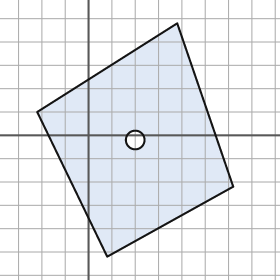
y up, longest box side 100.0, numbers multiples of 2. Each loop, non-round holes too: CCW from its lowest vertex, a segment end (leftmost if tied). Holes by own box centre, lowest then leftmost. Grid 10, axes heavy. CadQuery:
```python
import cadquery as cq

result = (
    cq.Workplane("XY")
    .moveTo(8.0, -52.0)
    .lineTo(62.0, -22.0)
    .lineTo(38.0, 48.0)
    .lineTo(-22.0, 10.0)
    .close()
    .moveTo(20.0, -2.0)
    .circle(4.0)
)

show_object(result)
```